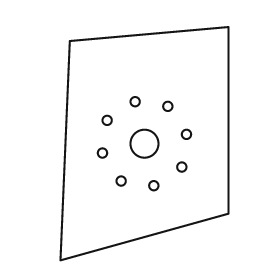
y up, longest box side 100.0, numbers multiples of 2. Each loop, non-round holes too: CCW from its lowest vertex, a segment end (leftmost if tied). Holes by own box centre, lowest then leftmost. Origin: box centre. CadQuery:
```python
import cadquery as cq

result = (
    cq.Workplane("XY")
    .moveTo(-36.0, -50.0)
    .lineTo(36.0, -30.0)
    .lineTo(36.0, 50.0)
    .lineTo(-32.0, 44.0)
    .close()
    .moveTo(4.0, -18.0)
    .circle(2.0)
    .moveTo(-10.0, -16.0)
    .circle(2.0)
    .moveTo(16.0, -10.0)
    .circle(2.0)
    .moveTo(-18.0, -4.0)
    .circle(2.0)
    .moveTo(0.0, 0.0)
    .circle(6.0)
    .moveTo(18.0, 4.0)
    .circle(2.0)
    .moveTo(-16.0, 10.0)
    .circle(2.0)
    .moveTo(10.0, 16.0)
    .circle(2.0)
    .moveTo(-4.0, 18.0)
    .circle(2.0)
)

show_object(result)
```